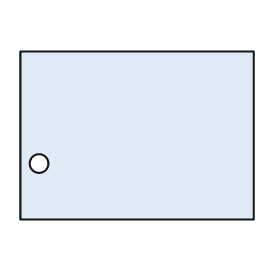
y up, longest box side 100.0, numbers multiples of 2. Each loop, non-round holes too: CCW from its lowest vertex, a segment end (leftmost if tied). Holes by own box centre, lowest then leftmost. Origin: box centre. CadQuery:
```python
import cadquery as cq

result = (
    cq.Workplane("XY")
    .moveTo(-50.0, -36.0)
    .lineTo(50.0, -36.0)
    .lineTo(50.0, 36.0)
    .lineTo(-50.0, 36.0)
    .close()
    .moveTo(-42.0, -12.0)
    .circle(4.0)
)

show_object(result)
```